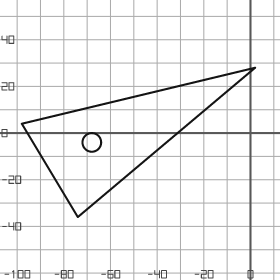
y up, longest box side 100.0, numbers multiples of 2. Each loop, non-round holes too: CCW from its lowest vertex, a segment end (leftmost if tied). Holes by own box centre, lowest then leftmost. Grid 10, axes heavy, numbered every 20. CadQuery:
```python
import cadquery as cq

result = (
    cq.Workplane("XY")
    .moveTo(-74.0, -36.0)
    .lineTo(2.0, 28.0)
    .lineTo(-98.0, 4.0)
    .close()
    .moveTo(-68.0, -4.0)
    .circle(4.0)
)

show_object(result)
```